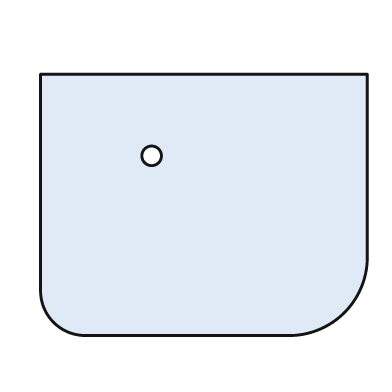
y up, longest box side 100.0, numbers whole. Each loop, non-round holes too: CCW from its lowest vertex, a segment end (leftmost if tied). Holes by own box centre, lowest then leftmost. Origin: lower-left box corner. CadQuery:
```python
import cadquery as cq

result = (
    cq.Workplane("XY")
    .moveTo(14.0, 0.0)
    .lineTo(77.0, 0.0)
    .threePointArc((93.0, 7.0), (100.0, 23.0))
    .lineTo(100.0, 80.0)
    .lineTo(0.0, 80.0)
    .lineTo(0.0, 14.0)
    .threePointArc((4.0, 4.0), (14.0, 0.0))
    .close()
    .moveTo(34.0, 55.0)
    .circle(3.0)
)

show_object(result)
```